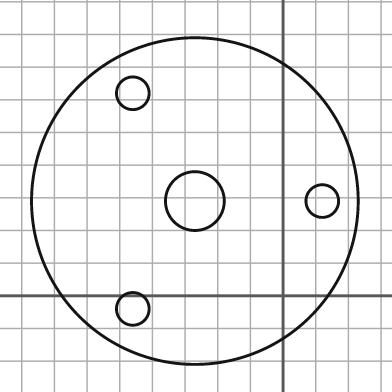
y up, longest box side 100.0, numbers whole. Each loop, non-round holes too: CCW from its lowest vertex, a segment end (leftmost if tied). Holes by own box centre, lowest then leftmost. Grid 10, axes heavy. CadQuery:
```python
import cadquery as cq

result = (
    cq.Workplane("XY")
    .moveTo(-27.0, 29.0)
    .circle(50.0)
    .moveTo(-46.0, -4.0)
    .circle(5.0)
    .moveTo(-27.0, 29.0)
    .circle(9.0)
    .moveTo(12.0, 29.0)
    .circle(5.0)
    .moveTo(-46.0, 62.0)
    .circle(5.0)
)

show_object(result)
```